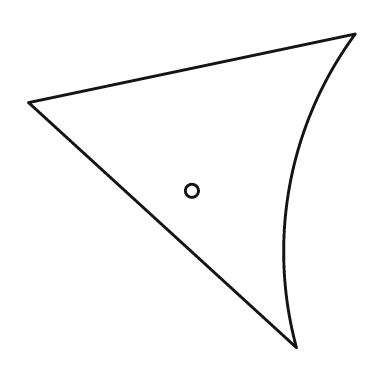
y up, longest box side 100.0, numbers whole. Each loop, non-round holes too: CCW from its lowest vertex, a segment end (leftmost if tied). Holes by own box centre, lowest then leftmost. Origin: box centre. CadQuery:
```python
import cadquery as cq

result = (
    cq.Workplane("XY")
    .moveTo(32.0, -48.0)
    .threePointArc((30.0, 2.0), (50.0, 48.0))
    .lineTo(-50.0, 27.0)
    .close()
    .moveTo(0.0, 0.0)
    .circle(2.0)
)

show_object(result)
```